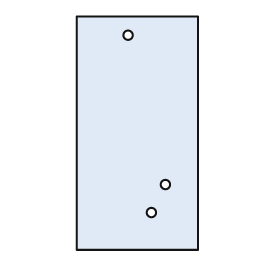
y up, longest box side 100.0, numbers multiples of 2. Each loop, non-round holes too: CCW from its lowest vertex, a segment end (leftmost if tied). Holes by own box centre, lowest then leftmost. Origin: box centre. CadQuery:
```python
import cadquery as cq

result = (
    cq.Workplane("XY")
    .moveTo(-26.0, -50.0)
    .lineTo(26.0, -50.0)
    .lineTo(26.0, 50.0)
    .lineTo(-26.0, 50.0)
    .close()
    .moveTo(6.0, -34.0)
    .circle(2.0)
    .moveTo(12.0, -22.0)
    .circle(2.0)
    .moveTo(-4.0, 42.0)
    .circle(2.0)
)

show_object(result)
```